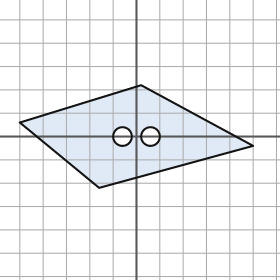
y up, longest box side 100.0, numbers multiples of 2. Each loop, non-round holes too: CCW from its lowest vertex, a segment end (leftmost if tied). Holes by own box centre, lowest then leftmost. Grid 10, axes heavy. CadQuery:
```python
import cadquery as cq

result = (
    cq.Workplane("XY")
    .moveTo(-16.0, -22.0)
    .lineTo(50.0, -4.0)
    .lineTo(2.0, 22.0)
    .lineTo(-50.0, 6.0)
    .close()
    .moveTo(-6.0, 0.0)
    .circle(4.0)
    .moveTo(6.0, 0.0)
    .circle(4.0)
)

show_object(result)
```